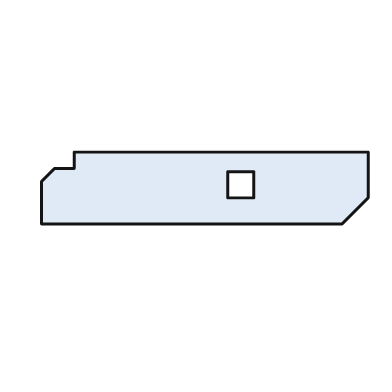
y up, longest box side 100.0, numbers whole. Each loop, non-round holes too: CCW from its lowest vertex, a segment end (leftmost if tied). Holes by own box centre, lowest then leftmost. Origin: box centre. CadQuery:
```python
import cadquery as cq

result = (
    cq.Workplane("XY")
    .moveTo(-50.0, -11.0)
    .lineTo(42.0, -11.0)
    .lineTo(50.0, -3.0)
    .lineTo(50.0, 11.0)
    .lineTo(-40.0, 11.0)
    .lineTo(-40.0, 6.0)
    .lineTo(-46.0, 6.0)
    .lineTo(-50.0, 2.0)
    .close()
    .moveTo(7.0, -3.0)
    .lineTo(15.0, -3.0)
    .lineTo(15.0, 5.0)
    .lineTo(7.0, 5.0)
    .close()
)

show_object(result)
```